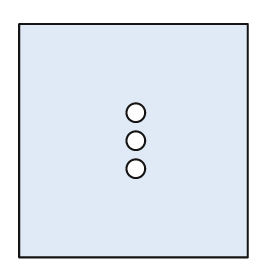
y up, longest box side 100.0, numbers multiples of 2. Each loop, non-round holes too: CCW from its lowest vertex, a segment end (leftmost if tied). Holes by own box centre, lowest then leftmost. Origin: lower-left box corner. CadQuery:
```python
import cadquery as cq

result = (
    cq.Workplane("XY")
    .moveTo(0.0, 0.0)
    .lineTo(98.0, 0.0)
    .lineTo(98.0, 100.0)
    .lineTo(0.0, 100.0)
    .close()
    .moveTo(50.0, 38.0)
    .circle(4.0)
    .moveTo(50.0, 50.0)
    .circle(4.0)
    .moveTo(50.0, 62.0)
    .circle(4.0)
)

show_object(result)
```